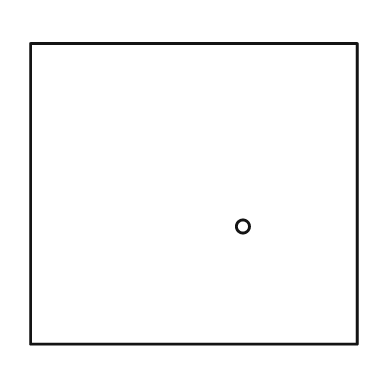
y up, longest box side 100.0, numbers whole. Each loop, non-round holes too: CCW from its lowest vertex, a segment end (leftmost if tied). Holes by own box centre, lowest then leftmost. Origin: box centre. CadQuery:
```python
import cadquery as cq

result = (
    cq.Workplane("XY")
    .moveTo(-50.0, -46.0)
    .lineTo(50.0, -46.0)
    .lineTo(50.0, 46.0)
    .lineTo(-50.0, 46.0)
    .close()
    .moveTo(15.0, -10.0)
    .circle(2.0)
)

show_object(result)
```